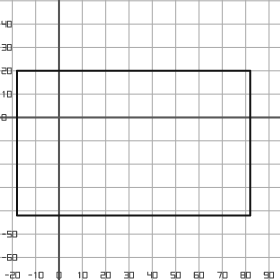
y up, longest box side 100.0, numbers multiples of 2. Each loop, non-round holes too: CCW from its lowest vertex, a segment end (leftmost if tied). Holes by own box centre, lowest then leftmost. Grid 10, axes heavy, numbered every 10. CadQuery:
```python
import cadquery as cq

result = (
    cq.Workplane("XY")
    .moveTo(-18.0, -42.0)
    .lineTo(82.0, -42.0)
    .lineTo(82.0, 20.0)
    .lineTo(-18.0, 20.0)
    .close()
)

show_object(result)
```